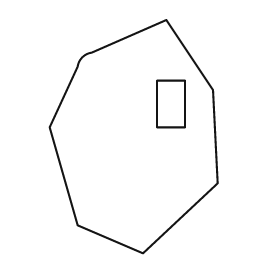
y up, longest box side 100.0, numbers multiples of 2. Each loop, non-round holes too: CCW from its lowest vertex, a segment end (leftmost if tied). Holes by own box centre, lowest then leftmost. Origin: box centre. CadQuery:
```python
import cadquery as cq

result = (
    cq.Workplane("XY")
    .moveTo(4.0, -50.0)
    .lineTo(36.0, -20.0)
    .lineTo(34.0, 20.0)
    .lineTo(14.0, 50.0)
    .lineTo(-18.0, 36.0)
    .threePointArc((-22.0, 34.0), (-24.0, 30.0))
    .lineTo(-36.0, 4.0)
    .lineTo(-24.0, -38.0)
    .close()
    .moveTo(10.0, 4.0)
    .lineTo(22.0, 4.0)
    .lineTo(22.0, 24.0)
    .lineTo(10.0, 24.0)
    .close()
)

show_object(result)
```